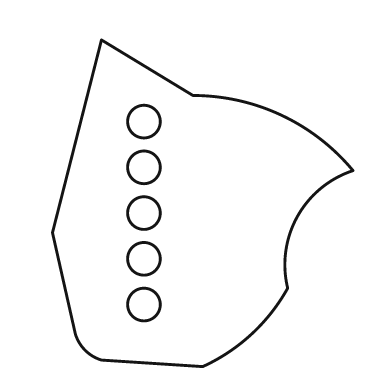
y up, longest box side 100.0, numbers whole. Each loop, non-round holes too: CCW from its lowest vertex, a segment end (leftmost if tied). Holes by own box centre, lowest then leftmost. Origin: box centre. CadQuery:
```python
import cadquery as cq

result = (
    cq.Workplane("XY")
    .moveTo(0.0, -50.0)
    .threePointArc((15.0, -40.0), (26.0, -26.0))
    .threePointArc((29.0, -4.0), (46.0, 10.0))
    .threePointArc((24.0, 27.0), (-3.0, 33.0))
    .lineTo(-31.0, 50.0)
    .lineTo(-46.0, -9.0)
    .lineTo(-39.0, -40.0)
    .threePointArc((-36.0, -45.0), (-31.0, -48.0))
    .close()
    .moveTo(-18.0, -31.0)
    .circle(5.0)
    .moveTo(-18.0, -17.0)
    .circle(5.0)
    .moveTo(-18.0, -3.0)
    .circle(5.0)
    .moveTo(-18.0, 11.0)
    .circle(5.0)
    .moveTo(-18.0, 25.0)
    .circle(5.0)
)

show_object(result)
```